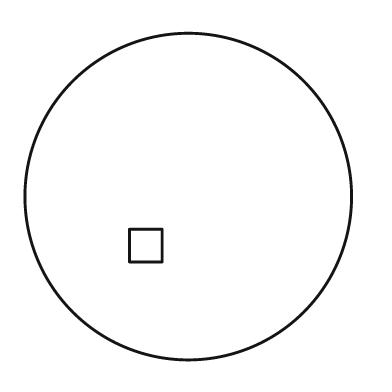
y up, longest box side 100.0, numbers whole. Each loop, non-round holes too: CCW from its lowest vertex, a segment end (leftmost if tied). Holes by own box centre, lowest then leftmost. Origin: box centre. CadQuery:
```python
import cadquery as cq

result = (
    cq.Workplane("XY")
    .moveTo(0.0, 0.0)
    .circle(50.0)
    .moveTo(-18.0, -20.0)
    .lineTo(-8.0, -20.0)
    .lineTo(-8.0, -10.0)
    .lineTo(-18.0, -10.0)
    .close()
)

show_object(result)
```